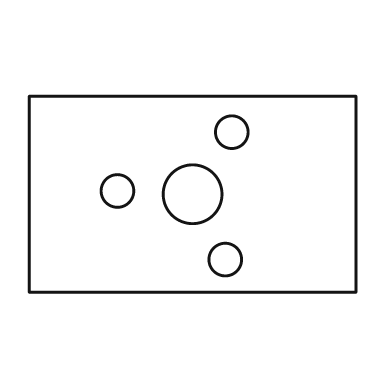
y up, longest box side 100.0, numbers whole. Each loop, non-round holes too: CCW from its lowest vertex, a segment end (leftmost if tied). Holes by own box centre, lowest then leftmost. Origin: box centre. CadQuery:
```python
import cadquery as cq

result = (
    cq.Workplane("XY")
    .moveTo(-50.0, -30.0)
    .lineTo(50.0, -30.0)
    .lineTo(50.0, 30.0)
    .lineTo(-50.0, 30.0)
    .close()
    .moveTo(10.0, -20.0)
    .circle(5.0)
    .moveTo(0.0, 0.0)
    .circle(9.0)
    .moveTo(-23.0, 1.0)
    .circle(5.0)
    .moveTo(12.0, 19.0)
    .circle(5.0)
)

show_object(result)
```